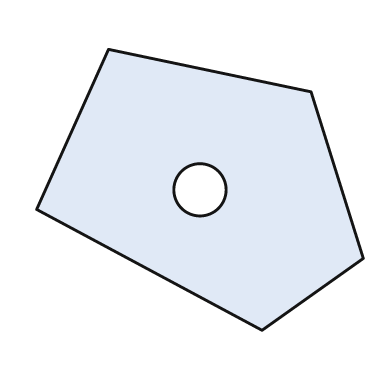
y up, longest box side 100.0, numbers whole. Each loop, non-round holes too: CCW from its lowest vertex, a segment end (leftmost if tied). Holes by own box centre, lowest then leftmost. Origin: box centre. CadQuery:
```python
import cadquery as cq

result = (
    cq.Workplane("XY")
    .moveTo(19.0, -43.0)
    .lineTo(50.0, -21.0)
    .lineTo(34.0, 30.0)
    .lineTo(-28.0, 43.0)
    .lineTo(-50.0, -6.0)
    .close()
    .moveTo(0.0, 0.0)
    .circle(8.0)
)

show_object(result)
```